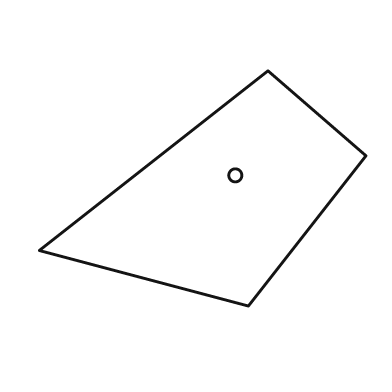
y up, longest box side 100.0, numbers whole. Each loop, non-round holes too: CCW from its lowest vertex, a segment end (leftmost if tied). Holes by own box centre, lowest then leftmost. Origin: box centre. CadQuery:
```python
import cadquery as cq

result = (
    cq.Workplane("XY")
    .moveTo(14.0, -36.0)
    .lineTo(50.0, 10.0)
    .lineTo(20.0, 36.0)
    .lineTo(-50.0, -19.0)
    .close()
    .moveTo(10.0, 4.0)
    .circle(2.0)
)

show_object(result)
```